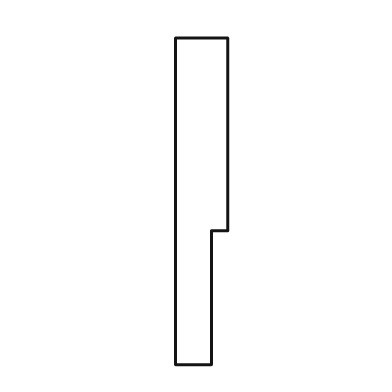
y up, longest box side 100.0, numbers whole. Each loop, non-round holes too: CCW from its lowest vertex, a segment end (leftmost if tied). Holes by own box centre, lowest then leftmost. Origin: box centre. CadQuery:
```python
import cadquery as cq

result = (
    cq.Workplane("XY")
    .moveTo(-8.0, -50.0)
    .lineTo(3.0, -50.0)
    .lineTo(3.0, -9.0)
    .lineTo(8.0, -9.0)
    .lineTo(8.0, 50.0)
    .lineTo(-8.0, 50.0)
    .close()
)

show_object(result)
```